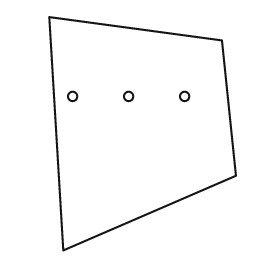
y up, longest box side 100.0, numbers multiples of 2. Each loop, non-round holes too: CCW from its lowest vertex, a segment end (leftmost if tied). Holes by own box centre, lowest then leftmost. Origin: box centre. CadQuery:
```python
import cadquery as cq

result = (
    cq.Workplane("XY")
    .moveTo(-34.0, -50.0)
    .lineTo(40.0, -18.0)
    .lineTo(34.0, 40.0)
    .lineTo(-40.0, 50.0)
    .close()
    .moveTo(-30.0, 16.0)
    .circle(2.0)
    .moveTo(-6.0, 16.0)
    .circle(2.0)
    .moveTo(18.0, 16.0)
    .circle(2.0)
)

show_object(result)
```